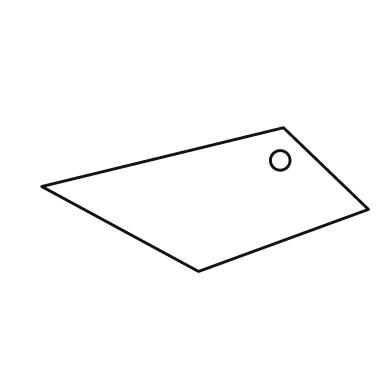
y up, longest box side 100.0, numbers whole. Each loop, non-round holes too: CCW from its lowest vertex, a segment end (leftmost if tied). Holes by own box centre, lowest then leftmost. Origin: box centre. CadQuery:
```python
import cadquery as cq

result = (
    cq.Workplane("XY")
    .moveTo(-2.0, -22.0)
    .lineTo(50.0, -3.0)
    .lineTo(24.0, 22.0)
    .lineTo(-50.0, 4.0)
    .close()
    .moveTo(23.0, 12.0)
    .circle(3.0)
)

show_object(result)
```